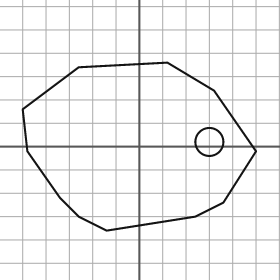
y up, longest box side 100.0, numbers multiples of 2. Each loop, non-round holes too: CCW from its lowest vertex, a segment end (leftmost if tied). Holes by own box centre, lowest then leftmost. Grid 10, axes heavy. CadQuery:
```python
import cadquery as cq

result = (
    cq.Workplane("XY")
    .moveTo(-14.0, -36.0)
    .lineTo(24.0, -30.0)
    .lineTo(36.0, -24.0)
    .lineTo(50.0, -2.0)
    .lineTo(32.0, 24.0)
    .lineTo(12.0, 36.0)
    .lineTo(-26.0, 34.0)
    .lineTo(-50.0, 16.0)
    .lineTo(-48.0, -2.0)
    .lineTo(-34.0, -22.0)
    .lineTo(-26.0, -30.0)
    .close()
    .moveTo(30.0, 2.0)
    .circle(6.0)
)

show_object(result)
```